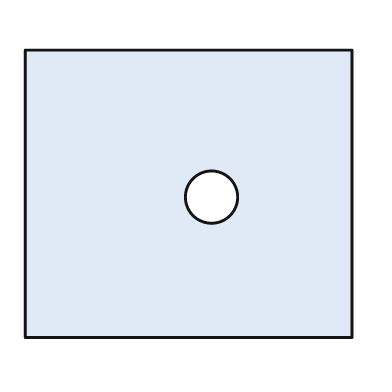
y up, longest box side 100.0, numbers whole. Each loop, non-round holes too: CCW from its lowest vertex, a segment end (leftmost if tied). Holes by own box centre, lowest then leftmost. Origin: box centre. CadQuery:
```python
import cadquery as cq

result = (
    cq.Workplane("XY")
    .moveTo(-50.0, -44.0)
    .lineTo(50.0, -44.0)
    .lineTo(50.0, 44.0)
    .lineTo(-50.0, 44.0)
    .close()
    .moveTo(7.0, -1.0)
    .circle(8.0)
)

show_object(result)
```